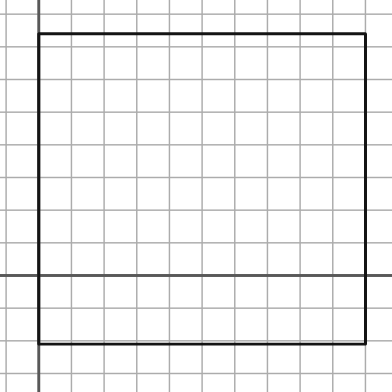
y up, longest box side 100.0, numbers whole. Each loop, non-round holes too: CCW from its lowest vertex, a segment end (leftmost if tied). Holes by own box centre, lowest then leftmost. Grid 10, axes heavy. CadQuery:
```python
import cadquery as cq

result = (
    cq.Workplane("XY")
    .moveTo(0.0, -21.0)
    .lineTo(100.0, -21.0)
    .lineTo(100.0, 74.0)
    .lineTo(0.0, 74.0)
    .close()
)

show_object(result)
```